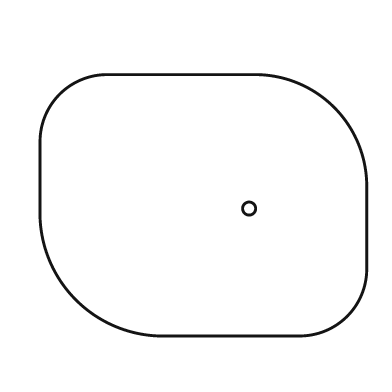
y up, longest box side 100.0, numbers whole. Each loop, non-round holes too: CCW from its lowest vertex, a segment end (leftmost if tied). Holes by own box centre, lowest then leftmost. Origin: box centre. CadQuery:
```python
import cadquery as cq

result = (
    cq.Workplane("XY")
    .moveTo(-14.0, -40.0)
    .lineTo(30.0, -40.0)
    .threePointArc((44.0, -34.0), (50.0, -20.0))
    .lineTo(50.0, 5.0)
    .threePointArc((40.0, 30.0), (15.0, 40.0))
    .lineTo(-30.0, 40.0)
    .threePointArc((-44.0, 34.0), (-50.0, 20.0))
    .lineTo(-50.0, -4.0)
    .threePointArc((-39.0, -29.0), (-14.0, -40.0))
    .close()
    .moveTo(14.0, -1.0)
    .circle(2.0)
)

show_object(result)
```